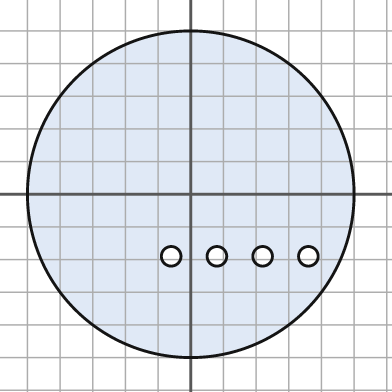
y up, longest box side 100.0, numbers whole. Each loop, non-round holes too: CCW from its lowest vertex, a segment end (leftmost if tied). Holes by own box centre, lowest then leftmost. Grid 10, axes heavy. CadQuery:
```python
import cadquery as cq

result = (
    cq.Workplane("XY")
    .moveTo(0.0, 0.0)
    .circle(50.0)
    .moveTo(-6.0, -19.0)
    .circle(3.0)
    .moveTo(8.0, -19.0)
    .circle(3.0)
    .moveTo(22.0, -19.0)
    .circle(3.0)
    .moveTo(36.0, -19.0)
    .circle(3.0)
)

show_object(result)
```